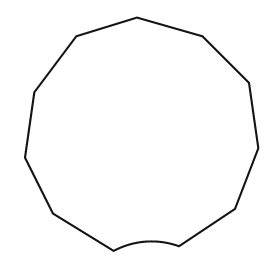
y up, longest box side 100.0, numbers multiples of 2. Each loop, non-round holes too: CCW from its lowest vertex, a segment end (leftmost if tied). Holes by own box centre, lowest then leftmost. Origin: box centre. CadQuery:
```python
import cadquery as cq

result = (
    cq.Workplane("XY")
    .moveTo(-12.0, -50.0)
    .threePointArc((2.0, -46.0), (16.0, -48.0))
    .lineTo(40.0, -32.0)
    .lineTo(50.0, -6.0)
    .lineTo(46.0, 22.0)
    .lineTo(26.0, 42.0)
    .lineTo(-2.0, 50.0)
    .lineTo(-28.0, 42.0)
    .lineTo(-46.0, 18.0)
    .lineTo(-50.0, -10.0)
    .lineTo(-38.0, -34.0)
    .close()
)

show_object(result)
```